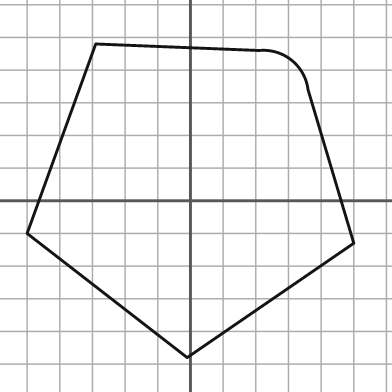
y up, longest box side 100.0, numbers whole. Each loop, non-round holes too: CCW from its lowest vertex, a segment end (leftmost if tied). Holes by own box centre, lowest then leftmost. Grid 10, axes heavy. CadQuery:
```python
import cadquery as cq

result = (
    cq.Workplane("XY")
    .moveTo(-1.0, -48.0)
    .lineTo(50.0, -13.0)
    .lineTo(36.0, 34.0)
    .threePointArc((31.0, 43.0), (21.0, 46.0))
    .lineTo(-29.0, 48.0)
    .lineTo(-50.0, -10.0)
    .close()
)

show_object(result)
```